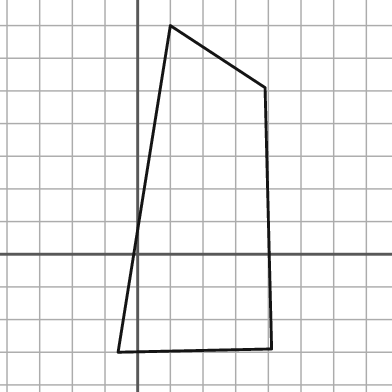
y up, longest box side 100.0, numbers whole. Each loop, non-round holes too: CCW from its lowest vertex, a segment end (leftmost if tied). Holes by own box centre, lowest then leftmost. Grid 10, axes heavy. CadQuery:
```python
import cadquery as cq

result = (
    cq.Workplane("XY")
    .moveTo(-6.0, -30.0)
    .lineTo(41.0, -29.0)
    .lineTo(39.0, 51.0)
    .lineTo(10.0, 70.0)
    .close()
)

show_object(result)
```